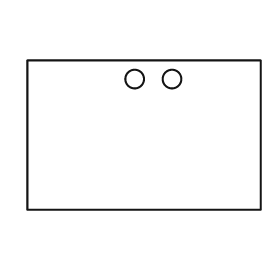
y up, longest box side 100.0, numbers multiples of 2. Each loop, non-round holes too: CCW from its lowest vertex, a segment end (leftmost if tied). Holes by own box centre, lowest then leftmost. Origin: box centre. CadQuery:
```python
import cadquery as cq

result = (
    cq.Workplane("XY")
    .moveTo(-50.0, -32.0)
    .lineTo(50.0, -32.0)
    .lineTo(50.0, 32.0)
    .lineTo(-50.0, 32.0)
    .close()
    .moveTo(-4.0, 24.0)
    .circle(4.0)
    .moveTo(12.0, 24.0)
    .circle(4.0)
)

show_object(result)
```